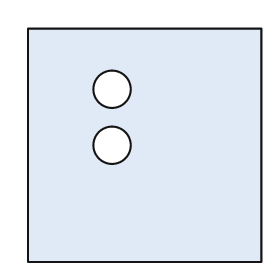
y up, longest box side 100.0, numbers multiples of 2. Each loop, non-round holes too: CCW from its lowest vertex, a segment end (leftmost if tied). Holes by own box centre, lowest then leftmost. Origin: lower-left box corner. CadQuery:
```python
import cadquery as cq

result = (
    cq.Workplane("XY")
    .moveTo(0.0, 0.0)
    .lineTo(100.0, 0.0)
    .lineTo(100.0, 100.0)
    .lineTo(0.0, 100.0)
    .close()
    .moveTo(36.0, 50.0)
    .circle(8.0)
    .moveTo(36.0, 74.0)
    .circle(8.0)
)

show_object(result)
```